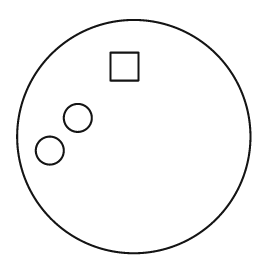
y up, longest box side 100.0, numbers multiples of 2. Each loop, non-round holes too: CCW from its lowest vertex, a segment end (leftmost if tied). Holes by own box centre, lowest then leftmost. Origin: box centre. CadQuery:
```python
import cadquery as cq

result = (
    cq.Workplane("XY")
    .moveTo(0.0, 0.0)
    .circle(50.0)
    .moveTo(-36.0, -6.0)
    .circle(6.0)
    .moveTo(-24.0, 8.0)
    .circle(6.0)
    .moveTo(-10.0, 24.0)
    .lineTo(2.0, 24.0)
    .lineTo(2.0, 36.0)
    .lineTo(-10.0, 36.0)
    .close()
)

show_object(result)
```